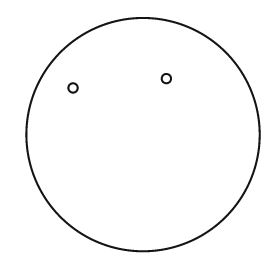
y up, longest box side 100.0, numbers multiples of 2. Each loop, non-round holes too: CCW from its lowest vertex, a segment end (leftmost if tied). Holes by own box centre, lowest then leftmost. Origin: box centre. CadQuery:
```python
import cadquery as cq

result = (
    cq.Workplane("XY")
    .moveTo(0.0, 0.0)
    .circle(50.0)
    .moveTo(-30.0, 20.0)
    .circle(2.0)
    .moveTo(10.0, 24.0)
    .circle(2.0)
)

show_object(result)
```